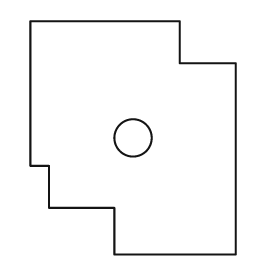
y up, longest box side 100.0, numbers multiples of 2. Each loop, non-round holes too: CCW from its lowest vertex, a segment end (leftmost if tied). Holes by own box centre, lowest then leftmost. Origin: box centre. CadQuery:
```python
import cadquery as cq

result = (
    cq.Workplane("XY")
    .moveTo(-8.0, -50.0)
    .lineTo(44.0, -50.0)
    .lineTo(44.0, 32.0)
    .lineTo(20.0, 32.0)
    .lineTo(20.0, 50.0)
    .lineTo(-44.0, 50.0)
    .lineTo(-44.0, -12.0)
    .lineTo(-36.0, -12.0)
    .lineTo(-36.0, -30.0)
    .lineTo(-8.0, -30.0)
    .close()
    .moveTo(0.0, 0.0)
    .circle(8.0)
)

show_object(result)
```